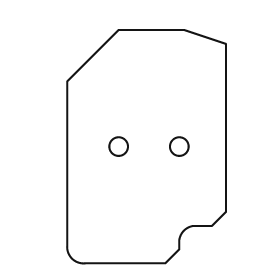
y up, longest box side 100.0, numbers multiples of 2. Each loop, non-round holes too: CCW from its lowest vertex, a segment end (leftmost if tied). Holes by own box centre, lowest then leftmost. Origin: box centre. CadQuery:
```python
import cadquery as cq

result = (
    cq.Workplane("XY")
    .moveTo(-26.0, -50.0)
    .lineTo(8.0, -50.0)
    .lineTo(14.0, -44.0)
    .lineTo(14.0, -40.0)
    .threePointArc((16.0, -36.0), (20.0, -34.0))
    .lineTo(28.0, -34.0)
    .lineTo(34.0, -28.0)
    .lineTo(34.0, 44.0)
    .lineTo(16.0, 50.0)
    .lineTo(-12.0, 50.0)
    .lineTo(-34.0, 28.0)
    .lineTo(-34.0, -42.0)
    .threePointArc((-32.0, -48.0), (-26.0, -50.0))
    .close()
    .moveTo(-12.0, 0.0)
    .circle(4.0)
    .moveTo(14.0, 0.0)
    .circle(4.0)
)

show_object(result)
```